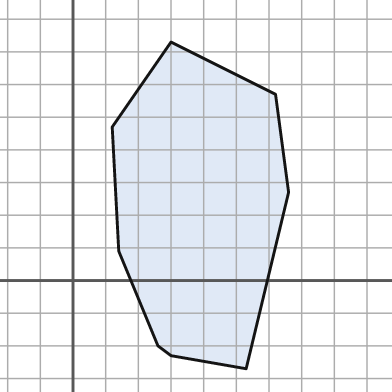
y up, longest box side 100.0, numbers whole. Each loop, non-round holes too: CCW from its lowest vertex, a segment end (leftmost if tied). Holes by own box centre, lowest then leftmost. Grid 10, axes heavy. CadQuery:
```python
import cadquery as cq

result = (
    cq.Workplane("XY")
    .moveTo(53.0, -27.0)
    .lineTo(66.0, 27.0)
    .lineTo(62.0, 57.0)
    .lineTo(30.0, 73.0)
    .lineTo(12.0, 47.0)
    .lineTo(14.0, 9.0)
    .lineTo(26.0, -20.0)
    .lineTo(30.0, -23.0)
    .close()
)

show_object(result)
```